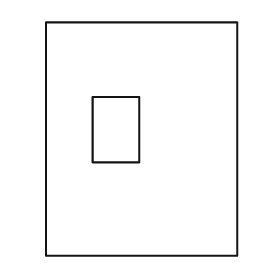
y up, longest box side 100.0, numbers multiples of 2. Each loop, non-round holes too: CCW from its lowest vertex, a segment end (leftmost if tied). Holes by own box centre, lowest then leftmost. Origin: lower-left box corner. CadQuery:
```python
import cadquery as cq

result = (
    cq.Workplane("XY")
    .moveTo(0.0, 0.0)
    .lineTo(82.0, 0.0)
    .lineTo(82.0, 100.0)
    .lineTo(0.0, 100.0)
    .close()
    .moveTo(20.0, 40.0)
    .lineTo(40.0, 40.0)
    .lineTo(40.0, 68.0)
    .lineTo(20.0, 68.0)
    .close()
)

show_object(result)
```